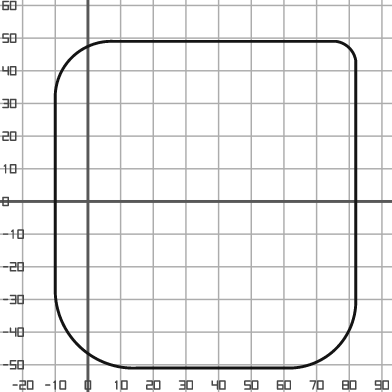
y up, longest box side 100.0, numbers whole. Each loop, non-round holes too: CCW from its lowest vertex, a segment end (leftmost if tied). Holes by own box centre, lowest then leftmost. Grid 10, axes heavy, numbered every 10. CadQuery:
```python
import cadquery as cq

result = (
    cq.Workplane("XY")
    .moveTo(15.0, -51.0)
    .lineTo(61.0, -51.0)
    .threePointArc((76.0, -45.0), (82.0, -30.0))
    .lineTo(82.0, 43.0)
    .threePointArc((80.0, 47.0), (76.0, 49.0))
    .lineTo(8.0, 49.0)
    .threePointArc((-5.0, 44.0), (-10.0, 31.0))
    .lineTo(-10.0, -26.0)
    .threePointArc((-3.0, -44.0), (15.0, -51.0))
    .close()
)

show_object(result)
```